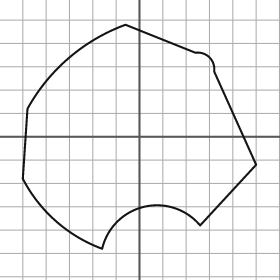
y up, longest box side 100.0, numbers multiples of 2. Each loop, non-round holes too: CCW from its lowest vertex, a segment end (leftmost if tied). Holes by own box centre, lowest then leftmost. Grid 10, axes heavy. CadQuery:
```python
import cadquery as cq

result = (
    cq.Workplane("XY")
    .moveTo(-16.0, -48.0)
    .threePointArc((2.0, -30.0), (26.0, -38.0))
    .lineTo(50.0, -12.0)
    .lineTo(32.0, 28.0)
    .threePointArc((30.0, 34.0), (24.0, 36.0))
    .lineTo(-6.0, 48.0)
    .threePointArc((-30.0, 34.0), (-48.0, 12.0))
    .lineTo(-50.0, -18.0)
    .threePointArc((-36.0, -36.0), (-16.0, -48.0))
    .close()
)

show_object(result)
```